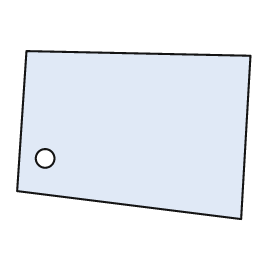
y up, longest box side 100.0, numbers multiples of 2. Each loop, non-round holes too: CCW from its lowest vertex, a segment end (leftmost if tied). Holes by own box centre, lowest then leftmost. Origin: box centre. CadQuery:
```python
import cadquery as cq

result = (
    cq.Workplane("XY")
    .moveTo(46.0, -36.0)
    .lineTo(50.0, 34.0)
    .lineTo(-46.0, 36.0)
    .lineTo(-50.0, -24.0)
    .close()
    .moveTo(-38.0, -10.0)
    .circle(4.0)
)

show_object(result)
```